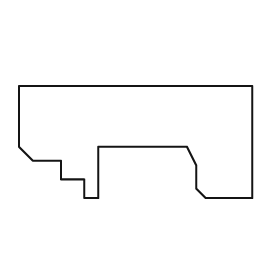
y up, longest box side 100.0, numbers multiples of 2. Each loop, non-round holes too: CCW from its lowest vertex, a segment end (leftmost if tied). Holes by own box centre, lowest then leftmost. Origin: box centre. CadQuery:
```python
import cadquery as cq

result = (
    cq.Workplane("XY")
    .moveTo(-22.0, -24.0)
    .lineTo(-16.0, -24.0)
    .lineTo(-16.0, -2.0)
    .lineTo(22.0, -2.0)
    .lineTo(26.0, -10.0)
    .lineTo(26.0, -20.0)
    .lineTo(30.0, -24.0)
    .lineTo(50.0, -24.0)
    .lineTo(50.0, 24.0)
    .lineTo(-50.0, 24.0)
    .lineTo(-50.0, -2.0)
    .lineTo(-44.0, -8.0)
    .lineTo(-32.0, -8.0)
    .lineTo(-32.0, -16.0)
    .lineTo(-22.0, -16.0)
    .close()
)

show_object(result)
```